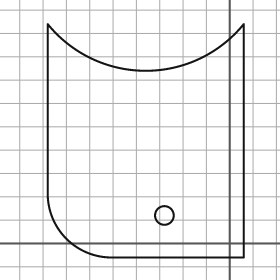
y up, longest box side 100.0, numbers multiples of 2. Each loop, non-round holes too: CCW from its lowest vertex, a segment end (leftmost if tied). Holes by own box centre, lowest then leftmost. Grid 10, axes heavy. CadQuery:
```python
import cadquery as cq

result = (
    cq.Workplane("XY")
    .moveTo(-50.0, -6.0)
    .lineTo(6.0, -6.0)
    .lineTo(6.0, 94.0)
    .threePointArc((-36.0, 74.0), (-78.0, 94.0))
    .lineTo(-78.0, 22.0)
    .threePointArc((-70.0, 2.0), (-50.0, -6.0))
    .close()
    .moveTo(-28.0, 12.0)
    .circle(4.0)
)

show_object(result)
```